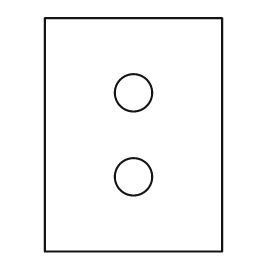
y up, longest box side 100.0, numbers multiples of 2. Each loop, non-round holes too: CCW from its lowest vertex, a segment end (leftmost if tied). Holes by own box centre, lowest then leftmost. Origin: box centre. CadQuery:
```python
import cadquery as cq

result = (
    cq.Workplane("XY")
    .moveTo(-38.0, -50.0)
    .lineTo(38.0, -50.0)
    .lineTo(38.0, 50.0)
    .lineTo(-38.0, 50.0)
    .close()
    .moveTo(0.0, -18.0)
    .circle(8.0)
    .moveTo(0.0, 18.0)
    .circle(8.0)
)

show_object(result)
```